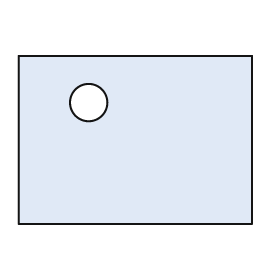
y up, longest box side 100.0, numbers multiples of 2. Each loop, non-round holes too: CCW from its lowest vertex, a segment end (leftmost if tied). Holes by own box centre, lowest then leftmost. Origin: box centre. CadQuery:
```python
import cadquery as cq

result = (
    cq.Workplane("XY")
    .moveTo(-50.0, -36.0)
    .lineTo(50.0, -36.0)
    .lineTo(50.0, 36.0)
    .lineTo(-50.0, 36.0)
    .close()
    .moveTo(-20.0, 16.0)
    .circle(8.0)
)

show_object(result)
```